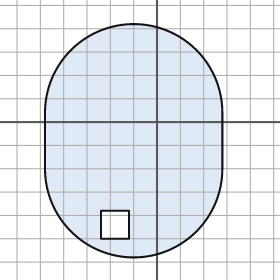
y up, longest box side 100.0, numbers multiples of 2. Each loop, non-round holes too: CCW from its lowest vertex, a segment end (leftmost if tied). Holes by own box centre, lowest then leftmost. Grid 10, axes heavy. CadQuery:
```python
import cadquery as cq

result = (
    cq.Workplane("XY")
    .moveTo(-48.0, -20.0)
    .threePointArc((-10.0, -58.0), (28.0, -20.0))
    .lineTo(28.0, 4.0)
    .threePointArc((-10.0, 42.0), (-48.0, 4.0))
    .close()
    .moveTo(-24.0, -50.0)
    .lineTo(-12.0, -50.0)
    .lineTo(-12.0, -38.0)
    .lineTo(-24.0, -38.0)
    .close()
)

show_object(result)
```